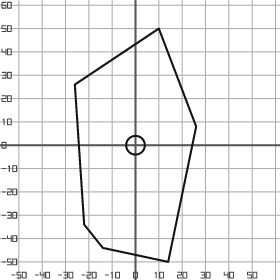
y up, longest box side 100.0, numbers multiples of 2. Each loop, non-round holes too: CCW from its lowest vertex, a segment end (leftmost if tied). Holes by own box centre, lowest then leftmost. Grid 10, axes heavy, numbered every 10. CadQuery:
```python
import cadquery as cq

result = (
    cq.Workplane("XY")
    .moveTo(14.0, -50.0)
    .lineTo(26.0, 8.0)
    .lineTo(10.0, 50.0)
    .lineTo(-26.0, 26.0)
    .lineTo(-22.0, -34.0)
    .lineTo(-14.0, -44.0)
    .close()
    .moveTo(0.0, 0.0)
    .circle(4.0)
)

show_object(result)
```